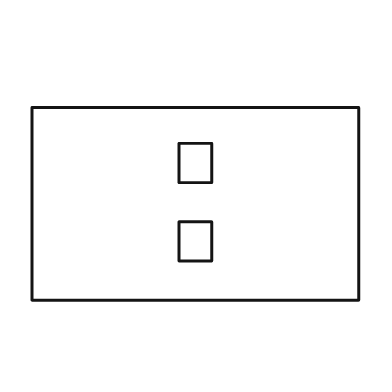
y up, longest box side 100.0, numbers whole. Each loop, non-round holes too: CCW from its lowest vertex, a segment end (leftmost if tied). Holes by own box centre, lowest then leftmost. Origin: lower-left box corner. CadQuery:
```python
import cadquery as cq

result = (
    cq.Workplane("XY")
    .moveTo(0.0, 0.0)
    .lineTo(100.0, 0.0)
    .lineTo(100.0, 59.0)
    .lineTo(0.0, 59.0)
    .close()
    .moveTo(45.0, 12.0)
    .lineTo(55.0, 12.0)
    .lineTo(55.0, 24.0)
    .lineTo(45.0, 24.0)
    .close()
    .moveTo(45.0, 36.0)
    .lineTo(55.0, 36.0)
    .lineTo(55.0, 48.0)
    .lineTo(45.0, 48.0)
    .close()
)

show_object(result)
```